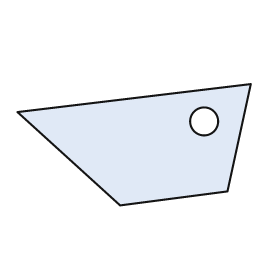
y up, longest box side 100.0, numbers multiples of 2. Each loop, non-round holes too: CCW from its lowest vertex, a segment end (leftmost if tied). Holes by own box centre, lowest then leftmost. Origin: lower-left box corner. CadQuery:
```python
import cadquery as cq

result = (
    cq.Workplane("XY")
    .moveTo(44.0, 0.0)
    .lineTo(90.0, 6.0)
    .lineTo(100.0, 52.0)
    .lineTo(0.0, 40.0)
    .close()
    .moveTo(80.0, 36.0)
    .circle(6.0)
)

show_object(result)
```